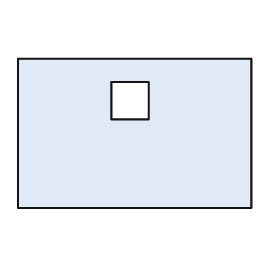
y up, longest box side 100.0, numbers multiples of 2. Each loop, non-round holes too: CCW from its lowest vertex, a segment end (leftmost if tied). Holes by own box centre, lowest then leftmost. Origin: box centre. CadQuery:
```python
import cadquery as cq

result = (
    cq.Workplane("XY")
    .moveTo(-50.0, -32.0)
    .lineTo(50.0, -32.0)
    .lineTo(50.0, 32.0)
    .lineTo(-50.0, 32.0)
    .close()
    .moveTo(-10.0, 6.0)
    .lineTo(6.0, 6.0)
    .lineTo(6.0, 22.0)
    .lineTo(-10.0, 22.0)
    .close()
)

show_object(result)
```